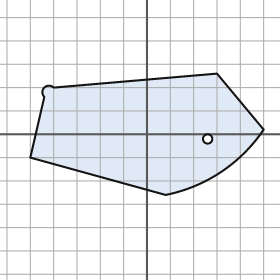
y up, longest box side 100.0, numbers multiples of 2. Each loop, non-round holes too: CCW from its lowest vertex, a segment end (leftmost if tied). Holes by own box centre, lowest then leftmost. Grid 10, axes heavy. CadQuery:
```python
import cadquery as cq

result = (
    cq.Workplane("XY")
    .moveTo(8.0, -26.0)
    .threePointArc((32.0, -16.0), (50.0, 2.0))
    .lineTo(30.0, 26.0)
    .lineTo(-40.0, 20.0)
    .threePointArc((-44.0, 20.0), (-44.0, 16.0))
    .lineTo(-50.0, -10.0)
    .close()
    .moveTo(26.0, -2.0)
    .circle(2.0)
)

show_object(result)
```